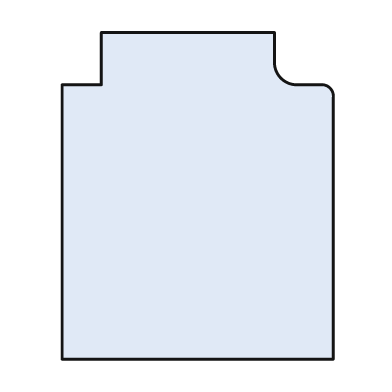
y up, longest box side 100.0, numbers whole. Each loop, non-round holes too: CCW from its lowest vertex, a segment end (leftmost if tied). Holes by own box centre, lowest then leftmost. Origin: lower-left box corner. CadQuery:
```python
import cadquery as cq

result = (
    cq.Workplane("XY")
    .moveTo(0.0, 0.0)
    .lineTo(83.0, 0.0)
    .lineTo(83.0, 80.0)
    .threePointArc((82.0, 83.0), (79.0, 84.0))
    .lineTo(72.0, 84.0)
    .threePointArc((67.0, 86.0), (65.0, 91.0))
    .lineTo(65.0, 100.0)
    .lineTo(12.0, 100.0)
    .lineTo(12.0, 84.0)
    .lineTo(0.0, 84.0)
    .close()
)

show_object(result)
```